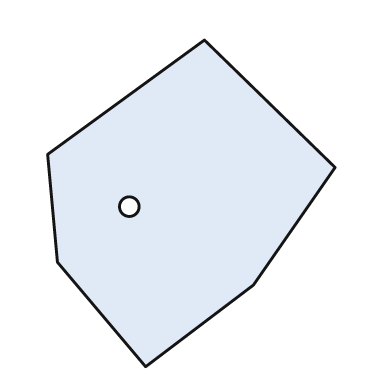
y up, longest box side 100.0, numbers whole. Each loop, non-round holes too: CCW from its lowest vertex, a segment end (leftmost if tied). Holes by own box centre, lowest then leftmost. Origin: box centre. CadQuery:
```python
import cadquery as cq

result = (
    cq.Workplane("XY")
    .moveTo(-14.0, -50.0)
    .lineTo(19.0, -25.0)
    .lineTo(44.0, 11.0)
    .lineTo(4.0, 50.0)
    .lineTo(-44.0, 15.0)
    .lineTo(-41.0, -18.0)
    .close()
    .moveTo(-19.0, -1.0)
    .circle(3.0)
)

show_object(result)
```